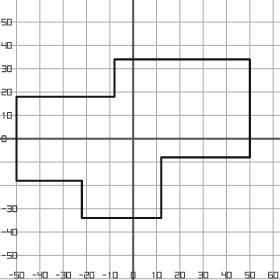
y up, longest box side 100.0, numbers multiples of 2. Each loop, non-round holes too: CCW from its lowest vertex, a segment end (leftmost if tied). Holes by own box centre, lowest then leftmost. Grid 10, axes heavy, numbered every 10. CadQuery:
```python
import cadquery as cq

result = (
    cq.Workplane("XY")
    .moveTo(-22.0, -34.0)
    .lineTo(12.0, -34.0)
    .lineTo(12.0, -8.0)
    .lineTo(50.0, -8.0)
    .lineTo(50.0, 34.0)
    .lineTo(-8.0, 34.0)
    .lineTo(-8.0, 18.0)
    .lineTo(-50.0, 18.0)
    .lineTo(-50.0, -18.0)
    .lineTo(-22.0, -18.0)
    .close()
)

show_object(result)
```